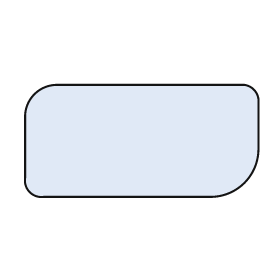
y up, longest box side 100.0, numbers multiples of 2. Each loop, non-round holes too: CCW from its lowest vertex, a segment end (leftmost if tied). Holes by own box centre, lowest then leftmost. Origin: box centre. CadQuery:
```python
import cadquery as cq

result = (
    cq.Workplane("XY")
    .moveTo(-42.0, -24.0)
    .lineTo(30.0, -24.0)
    .threePointArc((44.0, -18.0), (50.0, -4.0))
    .lineTo(50.0, 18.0)
    .threePointArc((48.0, 22.0), (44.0, 24.0))
    .lineTo(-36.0, 24.0)
    .threePointArc((-46.0, 20.0), (-50.0, 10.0))
    .lineTo(-50.0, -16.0)
    .threePointArc((-48.0, -22.0), (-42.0, -24.0))
    .close()
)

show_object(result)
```